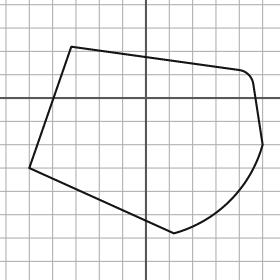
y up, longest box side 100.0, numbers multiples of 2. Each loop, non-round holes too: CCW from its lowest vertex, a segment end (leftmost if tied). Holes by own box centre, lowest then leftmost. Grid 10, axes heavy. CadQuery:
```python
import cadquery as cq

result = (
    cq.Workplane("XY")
    .moveTo(12.0, -58.0)
    .threePointArc((36.0, -44.0), (50.0, -20.0))
    .lineTo(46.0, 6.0)
    .threePointArc((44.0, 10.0), (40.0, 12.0))
    .lineTo(-32.0, 22.0)
    .lineTo(-50.0, -30.0)
    .close()
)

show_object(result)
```